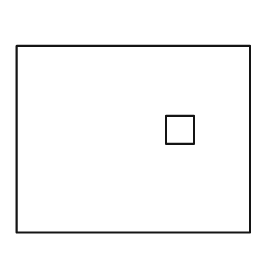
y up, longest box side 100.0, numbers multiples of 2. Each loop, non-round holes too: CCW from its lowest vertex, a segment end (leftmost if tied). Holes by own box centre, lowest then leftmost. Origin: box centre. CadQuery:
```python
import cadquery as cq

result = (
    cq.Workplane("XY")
    .moveTo(-50.0, -40.0)
    .lineTo(50.0, -40.0)
    .lineTo(50.0, 40.0)
    .lineTo(-50.0, 40.0)
    .close()
    .moveTo(14.0, -2.0)
    .lineTo(26.0, -2.0)
    .lineTo(26.0, 10.0)
    .lineTo(14.0, 10.0)
    .close()
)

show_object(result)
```